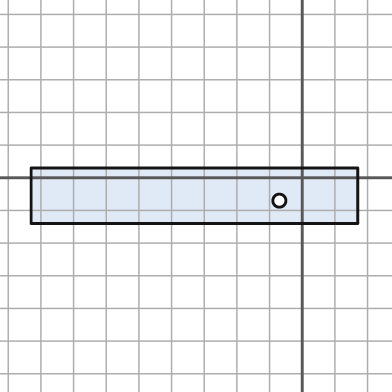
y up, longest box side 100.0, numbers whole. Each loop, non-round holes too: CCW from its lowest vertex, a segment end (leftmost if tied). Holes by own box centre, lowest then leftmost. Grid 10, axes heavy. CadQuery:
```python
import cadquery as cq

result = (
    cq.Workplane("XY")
    .moveTo(-83.0, -14.0)
    .lineTo(17.0, -14.0)
    .lineTo(17.0, 3.0)
    .lineTo(-83.0, 3.0)
    .close()
    .moveTo(-7.0, -7.0)
    .circle(2.0)
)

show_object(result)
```